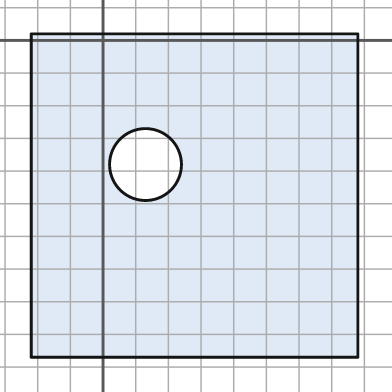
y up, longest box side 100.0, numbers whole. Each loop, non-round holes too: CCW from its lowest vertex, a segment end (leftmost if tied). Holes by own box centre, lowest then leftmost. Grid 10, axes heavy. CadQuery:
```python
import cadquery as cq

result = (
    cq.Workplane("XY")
    .moveTo(-22.0, -97.0)
    .lineTo(78.0, -97.0)
    .lineTo(78.0, 2.0)
    .lineTo(-22.0, 2.0)
    .close()
    .moveTo(13.0, -38.0)
    .circle(11.0)
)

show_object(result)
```